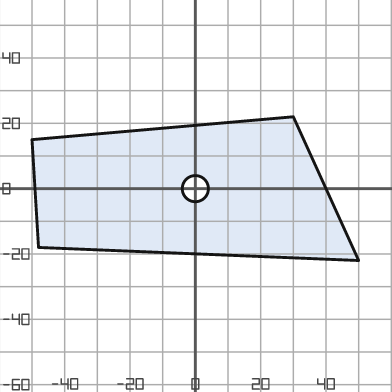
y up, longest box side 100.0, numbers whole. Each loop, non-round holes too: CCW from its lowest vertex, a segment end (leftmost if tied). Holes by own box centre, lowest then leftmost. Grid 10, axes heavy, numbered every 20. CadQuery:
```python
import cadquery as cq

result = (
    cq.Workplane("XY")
    .moveTo(50.0, -22.0)
    .lineTo(30.0, 22.0)
    .lineTo(-50.0, 15.0)
    .lineTo(-48.0, -18.0)
    .close()
    .moveTo(0.0, 0.0)
    .circle(4.0)
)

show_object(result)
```